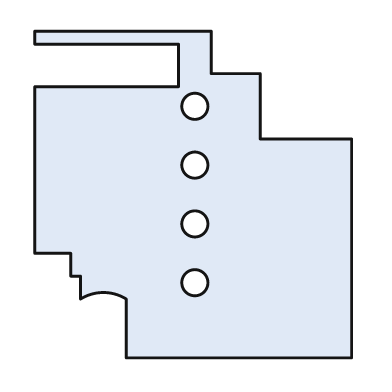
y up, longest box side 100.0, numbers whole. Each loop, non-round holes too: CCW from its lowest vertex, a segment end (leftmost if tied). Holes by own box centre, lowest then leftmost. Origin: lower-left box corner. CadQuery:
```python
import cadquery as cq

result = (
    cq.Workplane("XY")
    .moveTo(28.0, 0.0)
    .lineTo(97.0, 0.0)
    .lineTo(97.0, 67.0)
    .lineTo(69.0, 67.0)
    .lineTo(69.0, 87.0)
    .lineTo(54.0, 87.0)
    .lineTo(54.0, 100.0)
    .lineTo(0.0, 100.0)
    .lineTo(0.0, 96.0)
    .lineTo(44.0, 96.0)
    .lineTo(44.0, 83.0)
    .lineTo(0.0, 83.0)
    .lineTo(0.0, 32.0)
    .lineTo(11.0, 32.0)
    .lineTo(11.0, 25.0)
    .lineTo(14.0, 25.0)
    .lineTo(14.0, 18.0)
    .threePointArc((21.0, 20.0), (28.0, 18.0))
    .close()
    .moveTo(49.0, 23.0)
    .circle(4.0)
    .moveTo(49.0, 41.0)
    .circle(4.0)
    .moveTo(49.0, 59.0)
    .circle(4.0)
    .moveTo(49.0, 77.0)
    .circle(4.0)
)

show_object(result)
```